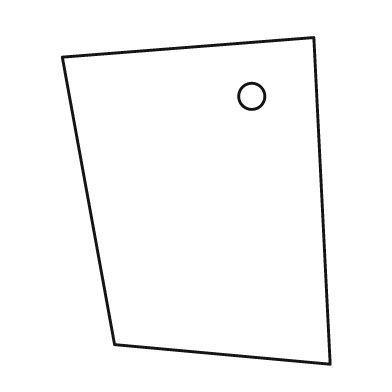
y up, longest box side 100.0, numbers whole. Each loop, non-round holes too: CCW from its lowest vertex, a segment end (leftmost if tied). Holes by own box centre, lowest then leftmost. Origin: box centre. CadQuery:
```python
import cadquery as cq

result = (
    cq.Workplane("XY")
    .moveTo(41.0, -50.0)
    .lineTo(36.0, 50.0)
    .lineTo(-41.0, 44.0)
    .lineTo(-25.0, -44.0)
    .close()
    .moveTo(17.0, 32.0)
    .circle(4.0)
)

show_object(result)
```